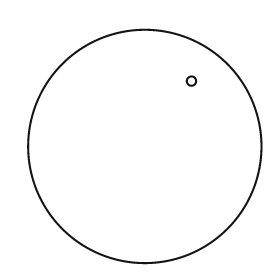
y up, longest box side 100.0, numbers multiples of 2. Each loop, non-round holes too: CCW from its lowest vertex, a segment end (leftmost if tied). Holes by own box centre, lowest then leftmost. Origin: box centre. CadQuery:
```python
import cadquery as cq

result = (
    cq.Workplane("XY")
    .moveTo(0.0, 0.0)
    .circle(50.0)
    .moveTo(20.0, 28.0)
    .circle(2.0)
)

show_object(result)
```